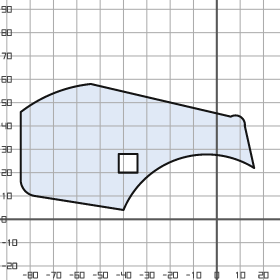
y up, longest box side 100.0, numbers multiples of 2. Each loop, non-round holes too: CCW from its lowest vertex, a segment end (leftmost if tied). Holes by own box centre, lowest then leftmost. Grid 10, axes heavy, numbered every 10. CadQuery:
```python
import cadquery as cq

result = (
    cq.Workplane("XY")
    .moveTo(-40.0, 4.0)
    .threePointArc((-16.0, 26.0), (16.0, 22.0))
    .lineTo(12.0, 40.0)
    .threePointArc((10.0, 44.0), (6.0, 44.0))
    .lineTo(-54.0, 58.0)
    .threePointArc((-70.0, 54.0), (-84.0, 46.0))
    .lineTo(-84.0, 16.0)
    .threePointArc((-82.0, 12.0), (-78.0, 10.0))
    .close()
    .moveTo(-42.0, 20.0)
    .lineTo(-34.0, 20.0)
    .lineTo(-34.0, 28.0)
    .lineTo(-42.0, 28.0)
    .close()
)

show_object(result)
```